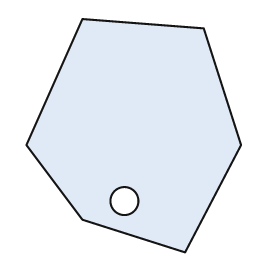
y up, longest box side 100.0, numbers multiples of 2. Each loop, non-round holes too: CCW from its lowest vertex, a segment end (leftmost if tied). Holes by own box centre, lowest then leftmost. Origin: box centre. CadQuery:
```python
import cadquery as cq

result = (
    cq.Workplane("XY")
    .moveTo(22.0, -50.0)
    .lineTo(46.0, -4.0)
    .lineTo(30.0, 46.0)
    .lineTo(-22.0, 50.0)
    .lineTo(-46.0, -4.0)
    .lineTo(-22.0, -36.0)
    .close()
    .moveTo(-4.0, -28.0)
    .circle(6.0)
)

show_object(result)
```